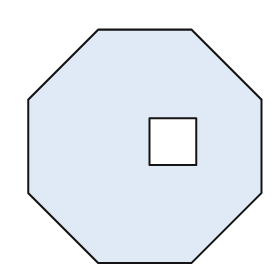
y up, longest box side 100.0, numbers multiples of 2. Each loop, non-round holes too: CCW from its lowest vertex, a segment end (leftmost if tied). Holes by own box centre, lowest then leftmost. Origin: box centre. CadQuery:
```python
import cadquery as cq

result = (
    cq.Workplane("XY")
    .moveTo(-20.0, -50.0)
    .lineTo(20.0, -50.0)
    .lineTo(50.0, -20.0)
    .lineTo(50.0, 20.0)
    .lineTo(20.0, 50.0)
    .lineTo(-20.0, 50.0)
    .lineTo(-50.0, 20.0)
    .lineTo(-50.0, -20.0)
    .close()
    .moveTo(2.0, -8.0)
    .lineTo(22.0, -8.0)
    .lineTo(22.0, 12.0)
    .lineTo(2.0, 12.0)
    .close()
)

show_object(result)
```